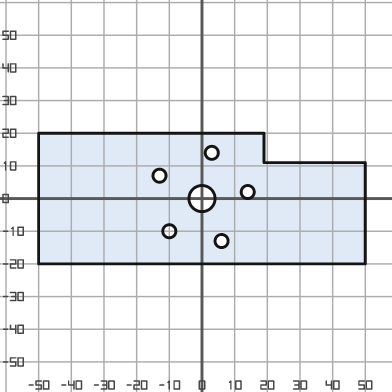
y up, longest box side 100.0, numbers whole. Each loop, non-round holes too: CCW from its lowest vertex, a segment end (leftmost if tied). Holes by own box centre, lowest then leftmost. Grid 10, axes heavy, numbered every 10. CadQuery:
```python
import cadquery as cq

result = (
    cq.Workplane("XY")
    .moveTo(-50.0, -20.0)
    .lineTo(50.0, -20.0)
    .lineTo(50.0, 11.0)
    .lineTo(19.0, 11.0)
    .lineTo(19.0, 20.0)
    .lineTo(-50.0, 20.0)
    .close()
    .moveTo(6.0, -13.0)
    .circle(2.0)
    .moveTo(-10.0, -10.0)
    .circle(2.0)
    .moveTo(0.0, 0.0)
    .circle(4.0)
    .moveTo(14.0, 2.0)
    .circle(2.0)
    .moveTo(-13.0, 7.0)
    .circle(2.0)
    .moveTo(3.0, 14.0)
    .circle(2.0)
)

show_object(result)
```